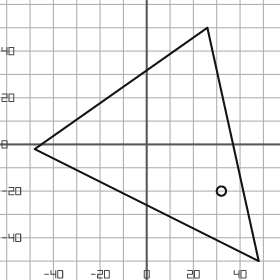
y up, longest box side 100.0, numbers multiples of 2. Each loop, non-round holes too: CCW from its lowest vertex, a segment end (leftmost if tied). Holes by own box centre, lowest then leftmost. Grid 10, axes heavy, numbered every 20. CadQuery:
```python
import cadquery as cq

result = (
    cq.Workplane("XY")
    .moveTo(48.0, -50.0)
    .lineTo(26.0, 50.0)
    .lineTo(-48.0, -2.0)
    .close()
    .moveTo(32.0, -20.0)
    .circle(2.0)
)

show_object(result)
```